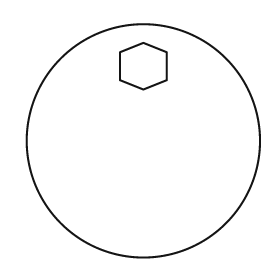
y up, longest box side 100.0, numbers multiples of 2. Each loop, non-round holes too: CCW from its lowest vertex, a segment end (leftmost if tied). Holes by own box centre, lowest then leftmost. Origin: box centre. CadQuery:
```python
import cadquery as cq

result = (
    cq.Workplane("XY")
    .moveTo(0.0, 0.0)
    .circle(50.0)
    .moveTo(0.0, 22.0)
    .lineTo(10.0, 26.0)
    .lineTo(10.0, 38.0)
    .lineTo(0.0, 42.0)
    .lineTo(-10.0, 38.0)
    .lineTo(-10.0, 26.0)
    .close()
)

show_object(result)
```